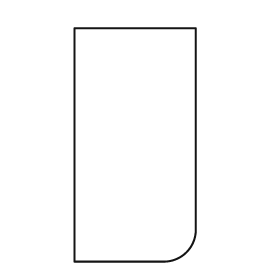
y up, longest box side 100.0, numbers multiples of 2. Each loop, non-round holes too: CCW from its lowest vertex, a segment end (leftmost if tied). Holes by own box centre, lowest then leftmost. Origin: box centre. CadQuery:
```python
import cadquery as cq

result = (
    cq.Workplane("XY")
    .moveTo(-26.0, -50.0)
    .lineTo(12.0, -50.0)
    .threePointArc((22.0, -46.0), (26.0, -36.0))
    .lineTo(26.0, 50.0)
    .lineTo(-26.0, 50.0)
    .close()
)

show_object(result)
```